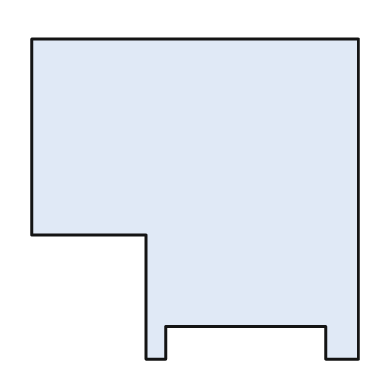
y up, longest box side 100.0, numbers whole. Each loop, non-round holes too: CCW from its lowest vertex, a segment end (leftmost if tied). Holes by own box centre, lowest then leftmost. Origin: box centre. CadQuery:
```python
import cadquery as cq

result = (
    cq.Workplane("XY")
    .moveTo(-15.0, -49.0)
    .lineTo(-9.0, -49.0)
    .lineTo(-9.0, -39.0)
    .lineTo(40.0, -39.0)
    .lineTo(40.0, -49.0)
    .lineTo(50.0, -49.0)
    .lineTo(50.0, 49.0)
    .lineTo(-50.0, 49.0)
    .lineTo(-50.0, -11.0)
    .lineTo(-15.0, -11.0)
    .close()
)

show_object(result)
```